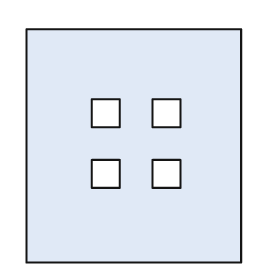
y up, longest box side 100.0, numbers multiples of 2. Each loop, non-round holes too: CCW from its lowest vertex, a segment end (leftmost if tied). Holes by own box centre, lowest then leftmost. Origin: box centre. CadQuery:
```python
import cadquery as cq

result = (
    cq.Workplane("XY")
    .moveTo(-46.0, -50.0)
    .lineTo(46.0, -50.0)
    .lineTo(46.0, 50.0)
    .lineTo(-46.0, 50.0)
    .close()
    .moveTo(-18.0, -18.0)
    .lineTo(-6.0, -18.0)
    .lineTo(-6.0, -6.0)
    .lineTo(-18.0, -6.0)
    .close()
    .moveTo(8.0, -18.0)
    .lineTo(20.0, -18.0)
    .lineTo(20.0, -6.0)
    .lineTo(8.0, -6.0)
    .close()
    .moveTo(-18.0, 8.0)
    .lineTo(-6.0, 8.0)
    .lineTo(-6.0, 20.0)
    .lineTo(-18.0, 20.0)
    .close()
    .moveTo(8.0, 8.0)
    .lineTo(20.0, 8.0)
    .lineTo(20.0, 20.0)
    .lineTo(8.0, 20.0)
    .close()
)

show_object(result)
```